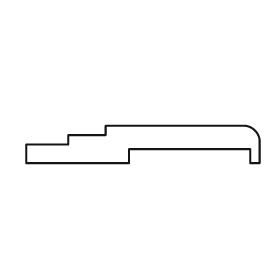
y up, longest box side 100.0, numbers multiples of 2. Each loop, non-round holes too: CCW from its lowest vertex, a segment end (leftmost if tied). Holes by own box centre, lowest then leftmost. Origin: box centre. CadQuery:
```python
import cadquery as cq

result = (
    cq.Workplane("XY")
    .moveTo(-50.0, -8.0)
    .lineTo(-6.0, -8.0)
    .lineTo(-6.0, -2.0)
    .lineTo(46.0, -2.0)
    .lineTo(46.0, -8.0)
    .lineTo(50.0, -8.0)
    .lineTo(50.0, 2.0)
    .threePointArc((48.0, 6.0), (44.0, 8.0))
    .lineTo(-16.0, 8.0)
    .lineTo(-16.0, 4.0)
    .lineTo(-32.0, 4.0)
    .lineTo(-32.0, 0.0)
    .lineTo(-50.0, 0.0)
    .close()
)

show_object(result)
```